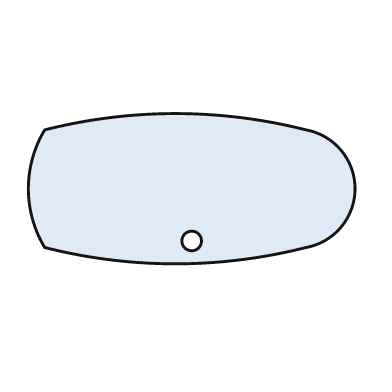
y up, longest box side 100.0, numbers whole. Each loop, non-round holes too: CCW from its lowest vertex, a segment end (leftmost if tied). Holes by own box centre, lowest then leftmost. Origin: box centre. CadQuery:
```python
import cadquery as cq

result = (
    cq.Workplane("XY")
    .moveTo(-45.0, -18.0)
    .threePointArc((-5.0, -23.0), (35.0, -18.0))
    .threePointArc((50.0, 0.0), (35.0, 18.0))
    .threePointArc((-5.0, 23.0), (-45.0, 18.0))
    .threePointArc((-50.0, 0.0), (-45.0, -18.0))
    .close()
    .moveTo(0.0, -16.0)
    .circle(3.0)
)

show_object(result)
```